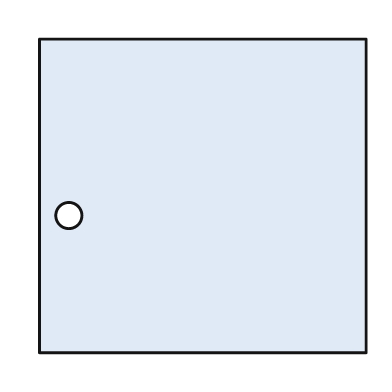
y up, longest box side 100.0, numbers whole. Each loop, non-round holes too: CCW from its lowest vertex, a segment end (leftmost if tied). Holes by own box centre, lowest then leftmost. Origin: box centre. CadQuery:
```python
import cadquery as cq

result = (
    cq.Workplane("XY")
    .moveTo(-50.0, -48.0)
    .lineTo(50.0, -48.0)
    .lineTo(50.0, 48.0)
    .lineTo(-50.0, 48.0)
    .close()
    .moveTo(-41.0, -6.0)
    .circle(4.0)
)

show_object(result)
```